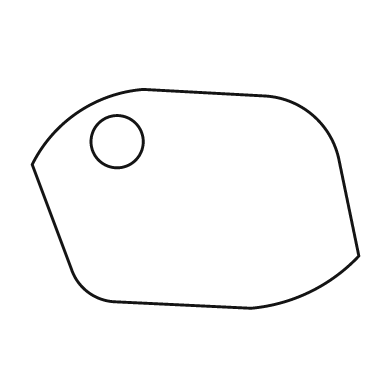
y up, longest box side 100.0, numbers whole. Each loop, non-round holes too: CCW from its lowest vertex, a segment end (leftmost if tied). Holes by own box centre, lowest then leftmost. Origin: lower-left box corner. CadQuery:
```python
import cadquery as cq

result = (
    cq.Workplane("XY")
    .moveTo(67.0, 0.0)
    .threePointArc((85.0, 5.0), (100.0, 16.0))
    .lineTo(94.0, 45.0)
    .threePointArc((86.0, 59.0), (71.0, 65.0))
    .lineTo(34.0, 67.0)
    .threePointArc((14.0, 60.0), (0.0, 44.0))
    .lineTo(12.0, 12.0)
    .threePointArc((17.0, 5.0), (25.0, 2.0))
    .close()
    .moveTo(26.0, 51.0)
    .circle(8.0)
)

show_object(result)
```